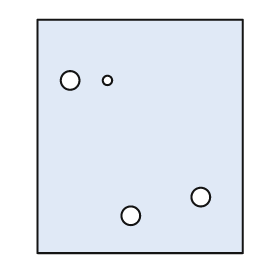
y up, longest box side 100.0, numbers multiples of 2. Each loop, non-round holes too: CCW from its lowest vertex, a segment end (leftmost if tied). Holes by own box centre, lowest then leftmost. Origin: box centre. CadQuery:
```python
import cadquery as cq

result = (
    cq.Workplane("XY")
    .moveTo(-44.0, -50.0)
    .lineTo(44.0, -50.0)
    .lineTo(44.0, 50.0)
    .lineTo(-44.0, 50.0)
    .close()
    .moveTo(-4.0, -34.0)
    .circle(4.0)
    .moveTo(26.0, -26.0)
    .circle(4.0)
    .moveTo(-30.0, 24.0)
    .circle(4.0)
    .moveTo(-14.0, 24.0)
    .circle(2.0)
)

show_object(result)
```